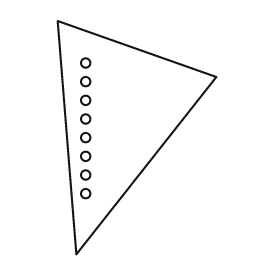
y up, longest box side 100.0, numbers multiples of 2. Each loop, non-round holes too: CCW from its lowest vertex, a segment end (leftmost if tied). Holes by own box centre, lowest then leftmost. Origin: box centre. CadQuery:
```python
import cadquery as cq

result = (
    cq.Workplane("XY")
    .moveTo(-26.0, -50.0)
    .lineTo(34.0, 26.0)
    .lineTo(-34.0, 50.0)
    .close()
    .moveTo(-22.0, -24.0)
    .circle(2.0)
    .moveTo(-22.0, -16.0)
    .circle(2.0)
    .moveTo(-22.0, -8.0)
    .circle(2.0)
    .moveTo(-22.0, 0.0)
    .circle(2.0)
    .moveTo(-22.0, 8.0)
    .circle(2.0)
    .moveTo(-22.0, 16.0)
    .circle(2.0)
    .moveTo(-22.0, 24.0)
    .circle(2.0)
    .moveTo(-22.0, 32.0)
    .circle(2.0)
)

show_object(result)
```